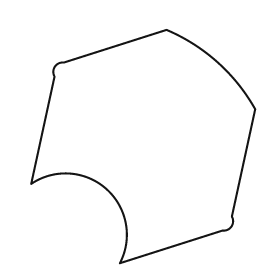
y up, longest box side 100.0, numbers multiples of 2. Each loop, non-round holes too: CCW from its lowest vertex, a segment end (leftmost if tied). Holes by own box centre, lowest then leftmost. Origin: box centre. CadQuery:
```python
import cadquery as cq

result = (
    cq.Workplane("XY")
    .moveTo(-10.0, -50.0)
    .lineTo(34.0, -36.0)
    .threePointArc((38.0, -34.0), (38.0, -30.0))
    .lineTo(48.0, 16.0)
    .threePointArc((32.0, 36.0), (10.0, 50.0))
    .lineTo(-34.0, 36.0)
    .threePointArc((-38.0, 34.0), (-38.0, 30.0))
    .lineTo(-48.0, -16.0)
    .threePointArc((-16.0, -18.0), (-10.0, -50.0))
    .close()
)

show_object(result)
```